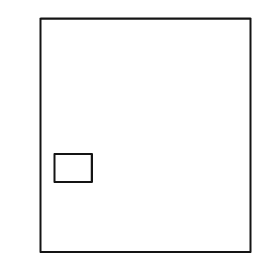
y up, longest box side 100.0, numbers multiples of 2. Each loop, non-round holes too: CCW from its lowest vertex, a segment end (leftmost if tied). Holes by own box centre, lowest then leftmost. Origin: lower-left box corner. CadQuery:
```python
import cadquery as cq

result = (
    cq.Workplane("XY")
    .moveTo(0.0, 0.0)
    .lineTo(90.0, 0.0)
    .lineTo(90.0, 100.0)
    .lineTo(0.0, 100.0)
    .close()
    .moveTo(6.0, 30.0)
    .lineTo(22.0, 30.0)
    .lineTo(22.0, 42.0)
    .lineTo(6.0, 42.0)
    .close()
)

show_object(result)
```